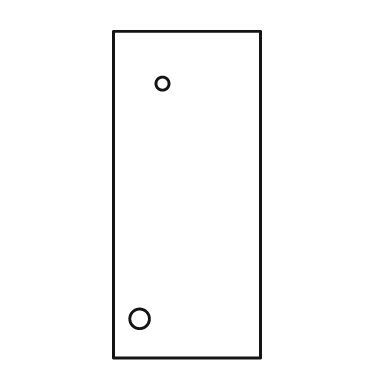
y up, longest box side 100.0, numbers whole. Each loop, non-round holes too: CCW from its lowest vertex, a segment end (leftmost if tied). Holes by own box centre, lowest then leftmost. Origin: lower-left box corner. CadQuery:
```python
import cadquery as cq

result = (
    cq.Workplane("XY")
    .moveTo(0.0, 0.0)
    .lineTo(45.0, 0.0)
    .lineTo(45.0, 100.0)
    .lineTo(0.0, 100.0)
    .close()
    .moveTo(8.0, 12.0)
    .circle(3.0)
    .moveTo(15.0, 84.0)
    .circle(2.0)
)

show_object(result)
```